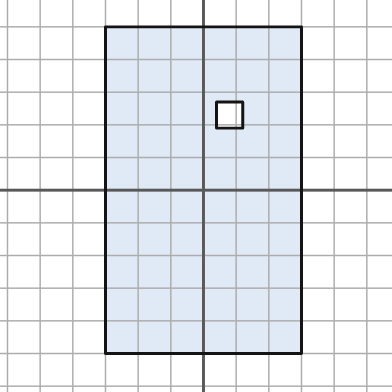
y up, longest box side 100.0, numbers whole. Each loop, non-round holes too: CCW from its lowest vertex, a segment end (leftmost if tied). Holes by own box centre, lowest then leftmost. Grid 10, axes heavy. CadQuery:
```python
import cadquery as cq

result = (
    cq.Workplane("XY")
    .moveTo(-30.0, -50.0)
    .lineTo(30.0, -50.0)
    .lineTo(30.0, 50.0)
    .lineTo(-30.0, 50.0)
    .close()
    .moveTo(4.0, 19.0)
    .lineTo(12.0, 19.0)
    .lineTo(12.0, 27.0)
    .lineTo(4.0, 27.0)
    .close()
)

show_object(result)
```